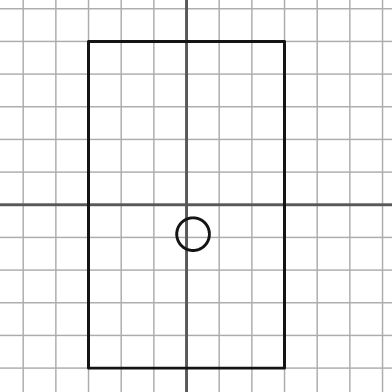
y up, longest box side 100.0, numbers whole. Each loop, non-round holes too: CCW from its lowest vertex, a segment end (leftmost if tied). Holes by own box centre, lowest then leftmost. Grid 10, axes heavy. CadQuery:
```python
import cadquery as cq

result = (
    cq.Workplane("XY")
    .moveTo(-30.0, -50.0)
    .lineTo(30.0, -50.0)
    .lineTo(30.0, 50.0)
    .lineTo(-30.0, 50.0)
    .close()
    .moveTo(2.0, -9.0)
    .circle(5.0)
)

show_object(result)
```